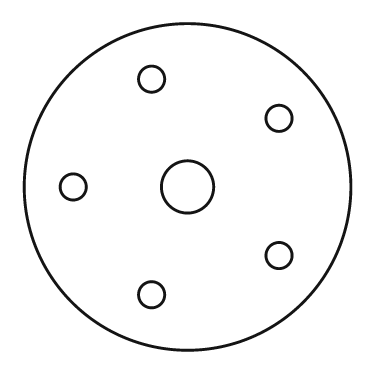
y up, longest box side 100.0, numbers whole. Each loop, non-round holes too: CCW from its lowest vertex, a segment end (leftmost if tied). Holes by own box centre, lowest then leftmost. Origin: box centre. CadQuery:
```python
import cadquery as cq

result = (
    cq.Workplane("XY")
    .moveTo(0.0, 0.0)
    .circle(50.0)
    .moveTo(-11.0, -33.0)
    .circle(4.0)
    .moveTo(28.0, -21.0)
    .circle(4.0)
    .moveTo(-35.0, 0.0)
    .circle(4.0)
    .moveTo(0.0, 0.0)
    .circle(8.0)
    .moveTo(28.0, 21.0)
    .circle(4.0)
    .moveTo(-11.0, 33.0)
    .circle(4.0)
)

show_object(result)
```